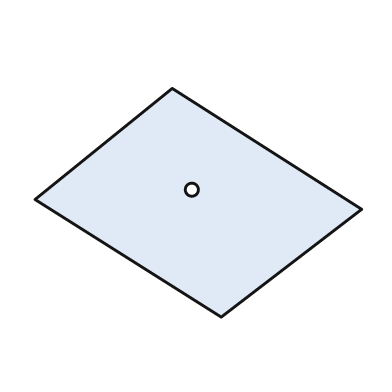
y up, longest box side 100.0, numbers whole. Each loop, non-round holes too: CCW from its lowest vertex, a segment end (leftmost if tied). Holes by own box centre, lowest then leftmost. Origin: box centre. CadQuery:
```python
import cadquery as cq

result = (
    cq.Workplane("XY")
    .moveTo(7.0, -35.0)
    .lineTo(50.0, -2.0)
    .lineTo(-8.0, 35.0)
    .lineTo(-50.0, 1.0)
    .close()
    .moveTo(-2.0, 4.0)
    .circle(2.0)
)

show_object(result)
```